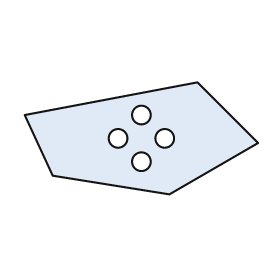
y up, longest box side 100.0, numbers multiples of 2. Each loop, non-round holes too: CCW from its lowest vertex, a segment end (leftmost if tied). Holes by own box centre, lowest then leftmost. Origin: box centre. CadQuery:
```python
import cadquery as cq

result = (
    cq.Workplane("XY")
    .moveTo(12.0, -24.0)
    .lineTo(50.0, -2.0)
    .lineTo(24.0, 24.0)
    .lineTo(-50.0, 10.0)
    .lineTo(-38.0, -16.0)
    .close()
    .moveTo(0.0, -10.0)
    .circle(4.0)
    .moveTo(-10.0, 0.0)
    .circle(4.0)
    .moveTo(10.0, 0.0)
    .circle(4.0)
    .moveTo(0.0, 10.0)
    .circle(4.0)
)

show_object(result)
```